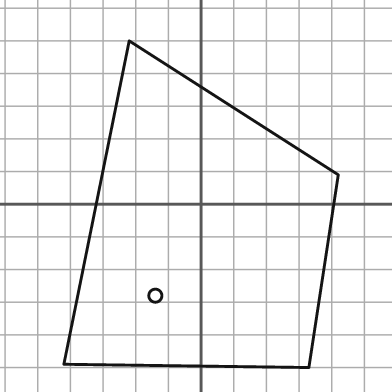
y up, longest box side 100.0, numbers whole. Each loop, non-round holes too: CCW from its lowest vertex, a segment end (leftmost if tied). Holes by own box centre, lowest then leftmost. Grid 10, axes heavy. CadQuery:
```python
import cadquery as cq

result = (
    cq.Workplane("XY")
    .moveTo(33.0, -50.0)
    .lineTo(42.0, 9.0)
    .lineTo(-22.0, 50.0)
    .lineTo(-42.0, -49.0)
    .close()
    .moveTo(-14.0, -28.0)
    .circle(2.0)
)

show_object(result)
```